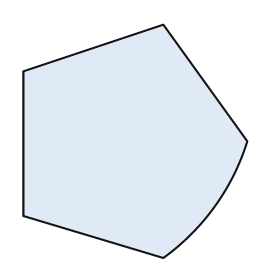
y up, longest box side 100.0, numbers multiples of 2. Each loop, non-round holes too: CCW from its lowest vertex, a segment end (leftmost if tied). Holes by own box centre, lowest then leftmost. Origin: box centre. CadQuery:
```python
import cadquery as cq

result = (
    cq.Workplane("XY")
    .moveTo(12.0, -50.0)
    .threePointArc((34.0, -28.0), (48.0, 0.0))
    .lineTo(12.0, 50.0)
    .lineTo(-48.0, 30.0)
    .lineTo(-48.0, -32.0)
    .close()
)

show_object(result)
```